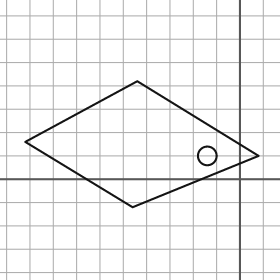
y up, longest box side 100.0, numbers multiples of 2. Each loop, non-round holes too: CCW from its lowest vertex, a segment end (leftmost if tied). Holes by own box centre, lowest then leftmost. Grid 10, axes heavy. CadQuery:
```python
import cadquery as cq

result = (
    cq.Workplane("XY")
    .moveTo(-46.0, -12.0)
    .lineTo(8.0, 10.0)
    .lineTo(-44.0, 42.0)
    .lineTo(-92.0, 16.0)
    .close()
    .moveTo(-14.0, 10.0)
    .circle(4.0)
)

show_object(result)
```